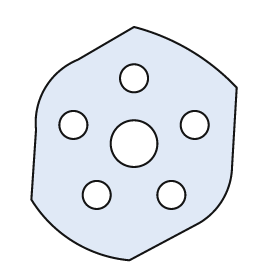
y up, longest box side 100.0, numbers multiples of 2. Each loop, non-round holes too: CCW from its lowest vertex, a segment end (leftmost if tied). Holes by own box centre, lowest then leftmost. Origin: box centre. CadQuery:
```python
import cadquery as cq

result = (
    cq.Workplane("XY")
    .moveTo(-2.0, -50.0)
    .lineTo(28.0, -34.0)
    .threePointArc((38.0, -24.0), (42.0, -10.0))
    .lineTo(44.0, 24.0)
    .threePointArc((24.0, 40.0), (0.0, 50.0))
    .lineTo(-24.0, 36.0)
    .threePointArc((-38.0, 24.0), (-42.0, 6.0))
    .lineTo(-44.0, -24.0)
    .threePointArc((-26.0, -42.0), (-2.0, -50.0))
    .close()
    .moveTo(-16.0, -22.0)
    .circle(6.0)
    .moveTo(16.0, -22.0)
    .circle(6.0)
    .moveTo(0.0, 0.0)
    .circle(10.0)
    .moveTo(-26.0, 8.0)
    .circle(6.0)
    .moveTo(26.0, 8.0)
    .circle(6.0)
    .moveTo(0.0, 28.0)
    .circle(6.0)
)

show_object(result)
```